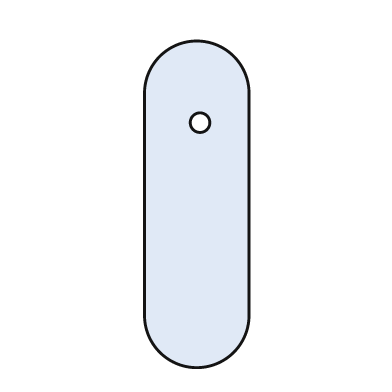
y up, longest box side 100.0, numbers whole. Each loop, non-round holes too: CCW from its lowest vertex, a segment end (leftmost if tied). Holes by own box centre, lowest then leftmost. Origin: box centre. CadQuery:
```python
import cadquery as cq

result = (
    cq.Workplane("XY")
    .moveTo(-16.0, -34.0)
    .threePointArc((0.0, -50.0), (16.0, -34.0))
    .lineTo(16.0, 34.0)
    .threePointArc((0.0, 50.0), (-16.0, 34.0))
    .close()
    .moveTo(1.0, 25.0)
    .circle(3.0)
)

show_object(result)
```